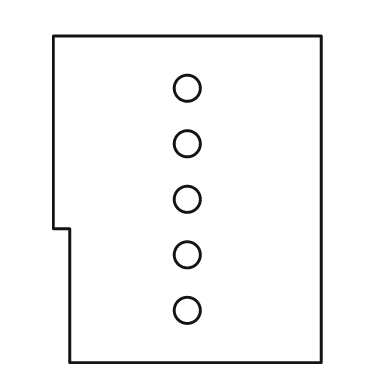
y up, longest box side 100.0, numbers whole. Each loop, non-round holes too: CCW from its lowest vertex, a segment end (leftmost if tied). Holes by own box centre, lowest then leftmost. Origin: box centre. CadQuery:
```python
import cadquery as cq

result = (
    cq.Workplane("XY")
    .moveTo(-36.0, -50.0)
    .lineTo(41.0, -50.0)
    .lineTo(41.0, 50.0)
    .lineTo(-41.0, 50.0)
    .lineTo(-41.0, -9.0)
    .lineTo(-36.0, -9.0)
    .close()
    .moveTo(0.0, -34.0)
    .circle(4.0)
    .moveTo(0.0, -17.0)
    .circle(4.0)
    .moveTo(0.0, 0.0)
    .circle(4.0)
    .moveTo(0.0, 17.0)
    .circle(4.0)
    .moveTo(0.0, 34.0)
    .circle(4.0)
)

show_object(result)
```